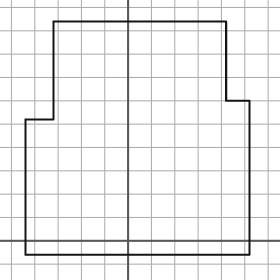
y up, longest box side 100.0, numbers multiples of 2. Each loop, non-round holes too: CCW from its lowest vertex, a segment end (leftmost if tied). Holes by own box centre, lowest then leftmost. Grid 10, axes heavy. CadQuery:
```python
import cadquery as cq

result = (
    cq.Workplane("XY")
    .moveTo(-44.0, -6.0)
    .lineTo(52.0, -6.0)
    .lineTo(52.0, 60.0)
    .lineTo(42.0, 60.0)
    .lineTo(42.0, 94.0)
    .lineTo(-32.0, 94.0)
    .lineTo(-32.0, 52.0)
    .lineTo(-44.0, 52.0)
    .close()
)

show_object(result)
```